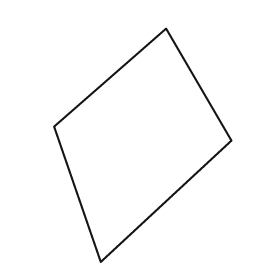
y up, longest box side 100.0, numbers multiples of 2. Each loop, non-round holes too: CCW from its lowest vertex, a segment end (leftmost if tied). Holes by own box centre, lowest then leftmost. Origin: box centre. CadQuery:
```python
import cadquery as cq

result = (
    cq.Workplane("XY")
    .moveTo(-18.0, -50.0)
    .lineTo(38.0, 2.0)
    .lineTo(10.0, 50.0)
    .lineTo(-38.0, 8.0)
    .close()
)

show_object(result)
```